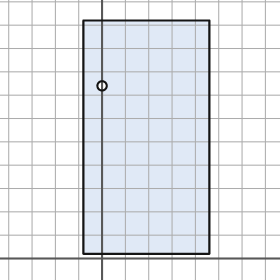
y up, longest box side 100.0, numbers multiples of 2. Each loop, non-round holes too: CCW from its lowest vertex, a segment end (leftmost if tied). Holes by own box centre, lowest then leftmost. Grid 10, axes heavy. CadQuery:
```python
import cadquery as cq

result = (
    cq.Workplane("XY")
    .moveTo(-8.0, 2.0)
    .lineTo(46.0, 2.0)
    .lineTo(46.0, 102.0)
    .lineTo(-8.0, 102.0)
    .close()
    .moveTo(0.0, 74.0)
    .circle(2.0)
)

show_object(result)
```